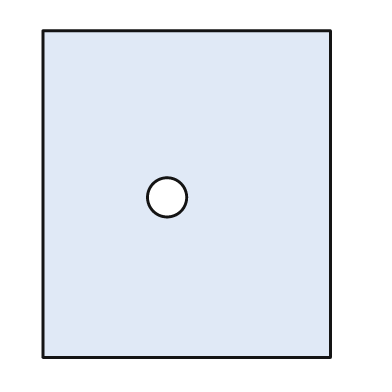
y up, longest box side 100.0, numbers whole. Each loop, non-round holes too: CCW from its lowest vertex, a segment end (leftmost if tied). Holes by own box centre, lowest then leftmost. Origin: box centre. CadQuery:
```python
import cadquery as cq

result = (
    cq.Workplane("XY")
    .moveTo(-44.0, -50.0)
    .lineTo(44.0, -50.0)
    .lineTo(44.0, 50.0)
    .lineTo(-44.0, 50.0)
    .close()
    .moveTo(-6.0, -1.0)
    .circle(6.0)
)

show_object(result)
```